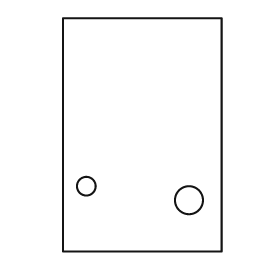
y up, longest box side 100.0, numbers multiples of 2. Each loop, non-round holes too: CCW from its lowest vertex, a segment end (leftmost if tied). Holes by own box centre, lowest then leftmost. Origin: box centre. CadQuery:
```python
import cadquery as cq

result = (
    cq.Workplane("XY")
    .moveTo(-34.0, -50.0)
    .lineTo(34.0, -50.0)
    .lineTo(34.0, 50.0)
    .lineTo(-34.0, 50.0)
    .close()
    .moveTo(20.0, -28.0)
    .circle(6.0)
    .moveTo(-24.0, -22.0)
    .circle(4.0)
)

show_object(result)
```